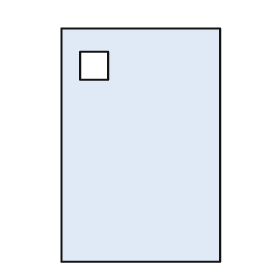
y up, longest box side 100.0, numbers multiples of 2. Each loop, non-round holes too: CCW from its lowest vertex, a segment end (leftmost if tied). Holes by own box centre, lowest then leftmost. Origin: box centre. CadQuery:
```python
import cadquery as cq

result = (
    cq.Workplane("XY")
    .moveTo(-34.0, -50.0)
    .lineTo(34.0, -50.0)
    .lineTo(34.0, 50.0)
    .lineTo(-34.0, 50.0)
    .close()
    .moveTo(-26.0, 28.0)
    .lineTo(-14.0, 28.0)
    .lineTo(-14.0, 40.0)
    .lineTo(-26.0, 40.0)
    .close()
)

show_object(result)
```